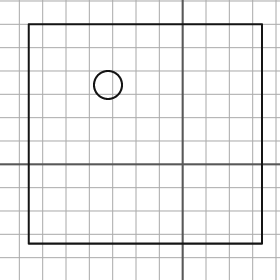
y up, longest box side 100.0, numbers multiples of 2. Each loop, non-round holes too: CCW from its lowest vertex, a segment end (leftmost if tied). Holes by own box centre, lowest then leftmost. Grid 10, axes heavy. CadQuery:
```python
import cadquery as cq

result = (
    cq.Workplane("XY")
    .moveTo(-66.0, -34.0)
    .lineTo(34.0, -34.0)
    .lineTo(34.0, 60.0)
    .lineTo(-66.0, 60.0)
    .close()
    .moveTo(-32.0, 34.0)
    .circle(6.0)
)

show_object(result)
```